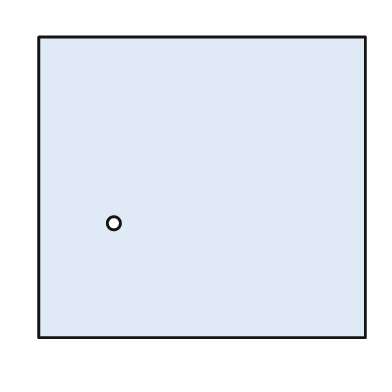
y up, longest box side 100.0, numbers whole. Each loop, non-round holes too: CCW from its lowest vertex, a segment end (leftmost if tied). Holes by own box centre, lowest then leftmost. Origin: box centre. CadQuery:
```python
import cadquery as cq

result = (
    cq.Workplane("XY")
    .moveTo(-50.0, -46.0)
    .lineTo(50.0, -46.0)
    .lineTo(50.0, 46.0)
    .lineTo(-50.0, 46.0)
    .close()
    .moveTo(-27.0, -11.0)
    .circle(2.0)
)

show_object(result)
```